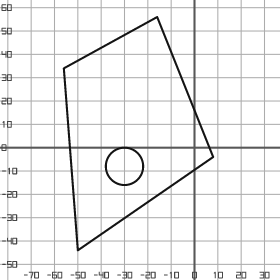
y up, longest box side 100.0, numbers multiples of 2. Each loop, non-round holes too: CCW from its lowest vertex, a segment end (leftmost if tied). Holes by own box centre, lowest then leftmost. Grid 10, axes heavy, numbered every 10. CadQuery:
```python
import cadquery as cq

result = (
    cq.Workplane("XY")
    .moveTo(-50.0, -44.0)
    .lineTo(8.0, -4.0)
    .lineTo(-16.0, 56.0)
    .lineTo(-56.0, 34.0)
    .close()
    .moveTo(-30.0, -8.0)
    .circle(8.0)
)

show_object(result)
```